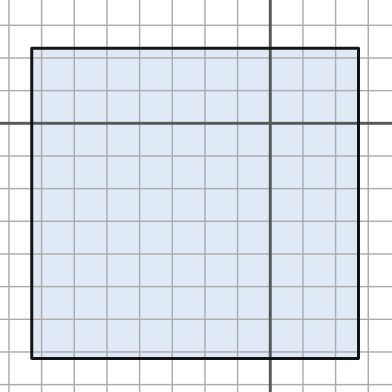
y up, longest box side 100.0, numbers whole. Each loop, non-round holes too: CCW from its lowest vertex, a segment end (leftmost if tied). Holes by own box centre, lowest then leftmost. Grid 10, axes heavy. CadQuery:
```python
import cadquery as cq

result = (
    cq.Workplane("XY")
    .moveTo(-73.0, -72.0)
    .lineTo(27.0, -72.0)
    .lineTo(27.0, 23.0)
    .lineTo(-73.0, 23.0)
    .close()
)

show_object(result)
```